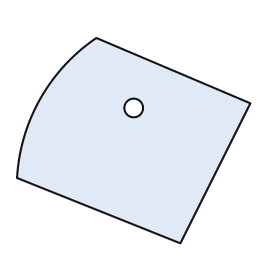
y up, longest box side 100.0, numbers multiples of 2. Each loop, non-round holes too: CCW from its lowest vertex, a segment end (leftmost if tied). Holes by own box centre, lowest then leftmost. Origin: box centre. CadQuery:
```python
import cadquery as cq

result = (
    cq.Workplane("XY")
    .moveTo(20.0, -44.0)
    .lineTo(50.0, 16.0)
    .lineTo(-16.0, 44.0)
    .threePointArc((-40.0, 18.0), (-50.0, -16.0))
    .close()
    .moveTo(0.0, 14.0)
    .circle(4.0)
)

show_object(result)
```